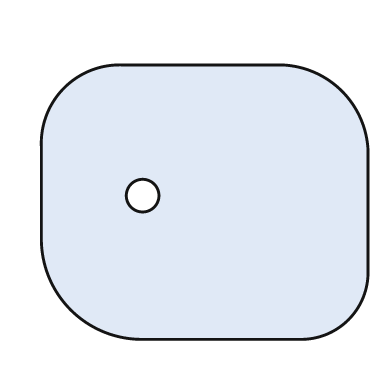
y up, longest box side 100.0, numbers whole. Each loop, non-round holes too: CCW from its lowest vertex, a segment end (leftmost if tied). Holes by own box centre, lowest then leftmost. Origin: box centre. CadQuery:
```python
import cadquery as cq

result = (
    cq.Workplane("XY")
    .moveTo(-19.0, -42.0)
    .lineTo(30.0, -42.0)
    .threePointArc((44.0, -36.0), (50.0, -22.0))
    .lineTo(50.0, 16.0)
    .threePointArc((42.0, 34.0), (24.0, 42.0))
    .lineTo(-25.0, 42.0)
    .threePointArc((-43.0, 35.0), (-50.0, 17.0))
    .lineTo(-50.0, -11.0)
    .threePointArc((-41.0, -33.0), (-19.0, -42.0))
    .close()
    .moveTo(-19.0, 2.0)
    .circle(5.0)
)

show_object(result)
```